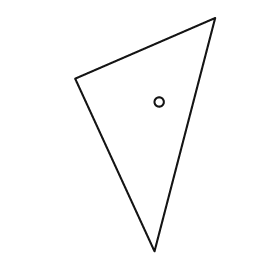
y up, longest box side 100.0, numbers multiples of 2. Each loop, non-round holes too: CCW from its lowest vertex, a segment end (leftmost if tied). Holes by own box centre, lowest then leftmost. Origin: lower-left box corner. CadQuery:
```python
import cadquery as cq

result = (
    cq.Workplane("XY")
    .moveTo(34.0, 0.0)
    .lineTo(60.0, 100.0)
    .lineTo(0.0, 74.0)
    .close()
    .moveTo(36.0, 64.0)
    .circle(2.0)
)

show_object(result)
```